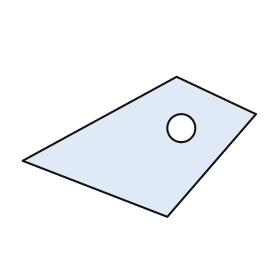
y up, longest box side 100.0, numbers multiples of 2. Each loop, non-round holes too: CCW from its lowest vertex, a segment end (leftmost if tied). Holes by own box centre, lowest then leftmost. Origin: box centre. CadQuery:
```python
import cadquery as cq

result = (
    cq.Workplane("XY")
    .moveTo(12.0, -30.0)
    .lineTo(50.0, 14.0)
    .lineTo(16.0, 30.0)
    .lineTo(-50.0, -6.0)
    .close()
    .moveTo(18.0, 8.0)
    .circle(6.0)
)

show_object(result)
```